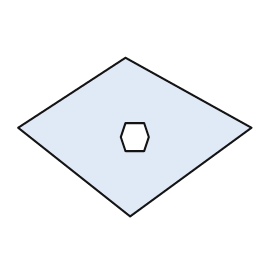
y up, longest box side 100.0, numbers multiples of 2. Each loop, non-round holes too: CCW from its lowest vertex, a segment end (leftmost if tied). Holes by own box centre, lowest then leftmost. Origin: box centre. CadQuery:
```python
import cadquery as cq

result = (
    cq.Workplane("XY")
    .moveTo(-2.0, -34.0)
    .lineTo(50.0, 4.0)
    .lineTo(-4.0, 34.0)
    .lineTo(-50.0, 4.0)
    .close()
    .moveTo(-4.0, -6.0)
    .lineTo(4.0, -6.0)
    .lineTo(6.0, 0.0)
    .lineTo(4.0, 6.0)
    .lineTo(-4.0, 6.0)
    .lineTo(-6.0, 0.0)
    .close()
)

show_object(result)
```